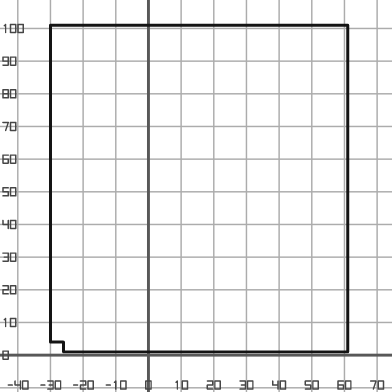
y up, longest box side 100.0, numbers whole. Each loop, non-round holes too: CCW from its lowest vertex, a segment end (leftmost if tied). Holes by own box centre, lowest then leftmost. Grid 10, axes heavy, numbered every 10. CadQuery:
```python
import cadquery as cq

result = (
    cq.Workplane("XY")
    .moveTo(-26.0, 1.0)
    .lineTo(61.0, 1.0)
    .lineTo(61.0, 101.0)
    .lineTo(-30.0, 101.0)
    .lineTo(-30.0, 4.0)
    .lineTo(-26.0, 4.0)
    .close()
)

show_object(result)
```